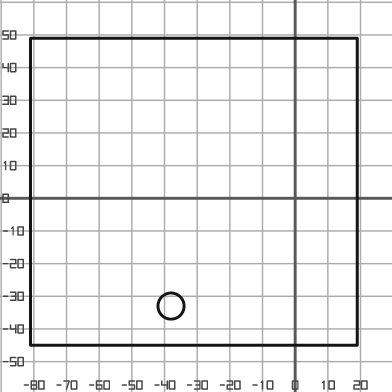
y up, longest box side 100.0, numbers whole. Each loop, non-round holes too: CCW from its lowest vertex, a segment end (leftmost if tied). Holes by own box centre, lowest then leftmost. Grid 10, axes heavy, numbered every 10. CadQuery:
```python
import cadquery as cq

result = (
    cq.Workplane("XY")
    .moveTo(-81.0, -45.0)
    .lineTo(19.0, -45.0)
    .lineTo(19.0, 49.0)
    .lineTo(-81.0, 49.0)
    .close()
    .moveTo(-38.0, -33.0)
    .circle(4.0)
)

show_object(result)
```